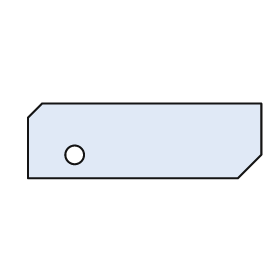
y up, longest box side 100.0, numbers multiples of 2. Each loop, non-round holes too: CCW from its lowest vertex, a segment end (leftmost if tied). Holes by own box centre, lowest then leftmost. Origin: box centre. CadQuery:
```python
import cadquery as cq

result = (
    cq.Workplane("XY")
    .moveTo(-50.0, -16.0)
    .lineTo(40.0, -16.0)
    .lineTo(50.0, -6.0)
    .lineTo(50.0, 16.0)
    .lineTo(-44.0, 16.0)
    .lineTo(-50.0, 10.0)
    .close()
    .moveTo(-30.0, -6.0)
    .circle(4.0)
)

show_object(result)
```